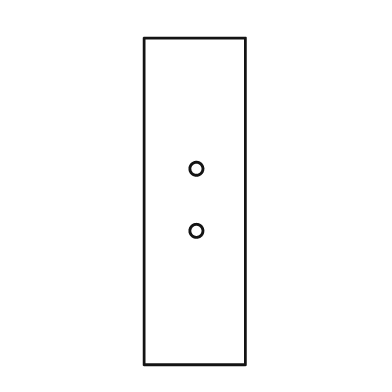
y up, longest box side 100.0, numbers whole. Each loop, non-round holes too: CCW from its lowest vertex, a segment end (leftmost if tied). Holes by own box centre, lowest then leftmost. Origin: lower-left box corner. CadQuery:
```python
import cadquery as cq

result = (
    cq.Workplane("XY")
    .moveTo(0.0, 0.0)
    .lineTo(31.0, 0.0)
    .lineTo(31.0, 100.0)
    .lineTo(0.0, 100.0)
    .close()
    .moveTo(16.0, 41.0)
    .circle(2.0)
    .moveTo(16.0, 60.0)
    .circle(2.0)
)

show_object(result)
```